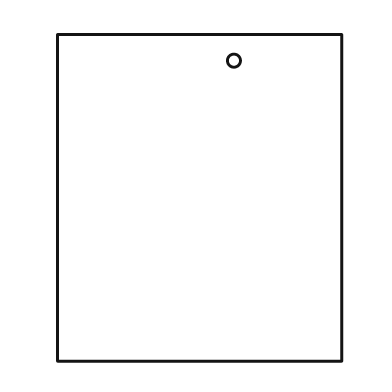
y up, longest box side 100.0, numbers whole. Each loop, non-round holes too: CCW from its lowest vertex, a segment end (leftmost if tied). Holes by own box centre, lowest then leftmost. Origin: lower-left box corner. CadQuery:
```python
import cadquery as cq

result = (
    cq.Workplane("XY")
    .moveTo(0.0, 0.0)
    .lineTo(87.0, 0.0)
    .lineTo(87.0, 100.0)
    .lineTo(0.0, 100.0)
    .close()
    .moveTo(54.0, 92.0)
    .circle(2.0)
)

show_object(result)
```